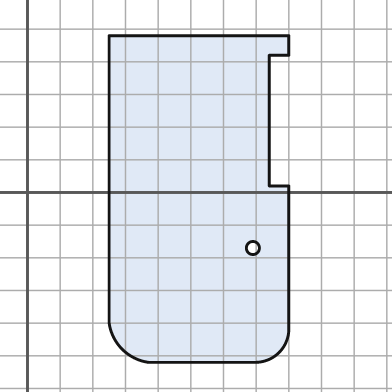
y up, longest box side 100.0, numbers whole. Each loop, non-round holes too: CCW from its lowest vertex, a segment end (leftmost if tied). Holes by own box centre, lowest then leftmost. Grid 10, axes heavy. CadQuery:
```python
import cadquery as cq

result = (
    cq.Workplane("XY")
    .moveTo(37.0, -52.0)
    .lineTo(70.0, -52.0)
    .threePointArc((77.0, -49.0), (80.0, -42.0))
    .lineTo(80.0, 2.0)
    .lineTo(74.0, 2.0)
    .lineTo(74.0, 42.0)
    .lineTo(80.0, 42.0)
    .lineTo(80.0, 48.0)
    .lineTo(25.0, 48.0)
    .lineTo(25.0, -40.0)
    .threePointArc((29.0, -48.0), (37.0, -52.0))
    .close()
    .moveTo(69.0, -17.0)
    .circle(2.0)
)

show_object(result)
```